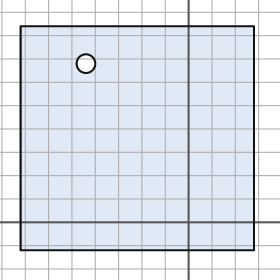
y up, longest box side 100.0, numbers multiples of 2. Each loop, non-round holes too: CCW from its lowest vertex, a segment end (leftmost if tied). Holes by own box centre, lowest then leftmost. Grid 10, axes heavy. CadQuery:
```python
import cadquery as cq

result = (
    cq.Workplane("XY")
    .moveTo(-72.0, -12.0)
    .lineTo(28.0, -12.0)
    .lineTo(28.0, 84.0)
    .lineTo(-72.0, 84.0)
    .close()
    .moveTo(-44.0, 68.0)
    .circle(4.0)
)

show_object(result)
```